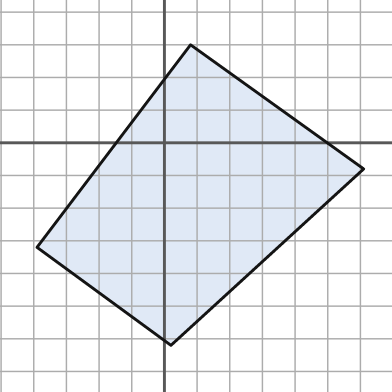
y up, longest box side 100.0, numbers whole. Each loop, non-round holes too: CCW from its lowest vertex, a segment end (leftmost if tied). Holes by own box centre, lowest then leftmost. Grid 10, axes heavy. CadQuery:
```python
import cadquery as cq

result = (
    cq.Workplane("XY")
    .moveTo(2.0, -62.0)
    .lineTo(61.0, -8.0)
    .lineTo(8.0, 30.0)
    .lineTo(-39.0, -32.0)
    .close()
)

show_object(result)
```